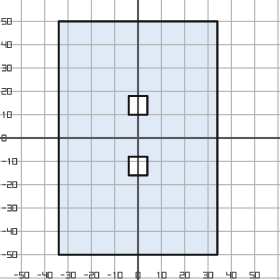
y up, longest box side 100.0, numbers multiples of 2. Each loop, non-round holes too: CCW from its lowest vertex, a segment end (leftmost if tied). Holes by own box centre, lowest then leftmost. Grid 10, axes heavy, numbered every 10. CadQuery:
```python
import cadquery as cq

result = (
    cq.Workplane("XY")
    .moveTo(-34.0, -50.0)
    .lineTo(34.0, -50.0)
    .lineTo(34.0, 50.0)
    .lineTo(-34.0, 50.0)
    .close()
    .moveTo(-4.0, -16.0)
    .lineTo(4.0, -16.0)
    .lineTo(4.0, -8.0)
    .lineTo(-4.0, -8.0)
    .close()
    .moveTo(-4.0, 10.0)
    .lineTo(4.0, 10.0)
    .lineTo(4.0, 18.0)
    .lineTo(-4.0, 18.0)
    .close()
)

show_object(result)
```